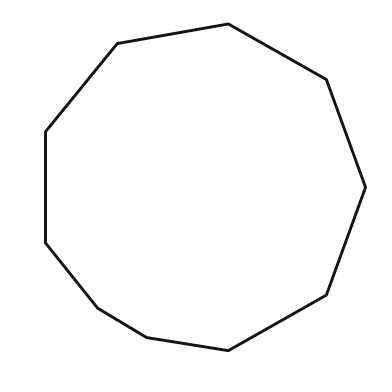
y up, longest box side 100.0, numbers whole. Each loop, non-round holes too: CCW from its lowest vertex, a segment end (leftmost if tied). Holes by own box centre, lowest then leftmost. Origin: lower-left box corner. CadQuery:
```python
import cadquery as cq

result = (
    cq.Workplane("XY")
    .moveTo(56.0, 0.0)
    .lineTo(86.0, 17.0)
    .lineTo(98.0, 50.0)
    .lineTo(86.0, 83.0)
    .lineTo(56.0, 100.0)
    .lineTo(22.0, 94.0)
    .lineTo(0.0, 67.0)
    .lineTo(0.0, 33.0)
    .lineTo(16.0, 13.0)
    .lineTo(31.0, 4.0)
    .close()
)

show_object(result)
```